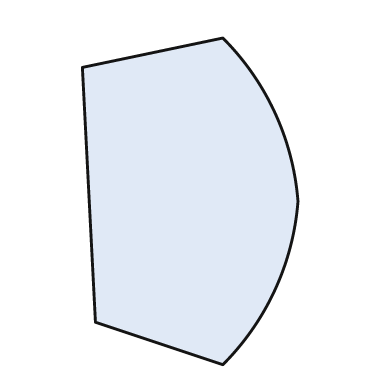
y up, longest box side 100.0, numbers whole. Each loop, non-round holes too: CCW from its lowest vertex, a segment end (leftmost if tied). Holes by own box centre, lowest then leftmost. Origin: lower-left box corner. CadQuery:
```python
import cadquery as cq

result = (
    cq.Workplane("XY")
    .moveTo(43.0, 0.0)
    .threePointArc((59.0, 23.0), (66.0, 50.0))
    .threePointArc((59.0, 77.0), (43.0, 100.0))
    .lineTo(0.0, 91.0)
    .lineTo(4.0, 13.0)
    .close()
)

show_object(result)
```